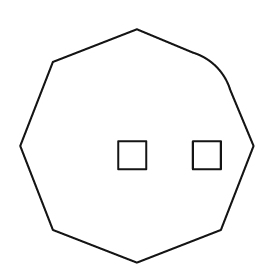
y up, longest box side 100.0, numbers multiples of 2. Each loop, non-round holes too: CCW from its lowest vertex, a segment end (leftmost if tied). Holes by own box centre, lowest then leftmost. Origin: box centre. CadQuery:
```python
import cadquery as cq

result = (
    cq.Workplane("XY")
    .moveTo(0.0, -50.0)
    .lineTo(36.0, -36.0)
    .lineTo(50.0, 0.0)
    .lineTo(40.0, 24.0)
    .threePointArc((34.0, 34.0), (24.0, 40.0))
    .lineTo(0.0, 50.0)
    .lineTo(-36.0, 36.0)
    .lineTo(-50.0, 0.0)
    .lineTo(-36.0, -36.0)
    .close()
    .moveTo(-8.0, -10.0)
    .lineTo(4.0, -10.0)
    .lineTo(4.0, 2.0)
    .lineTo(-8.0, 2.0)
    .close()
    .moveTo(24.0, -10.0)
    .lineTo(36.0, -10.0)
    .lineTo(36.0, 2.0)
    .lineTo(24.0, 2.0)
    .close()
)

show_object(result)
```